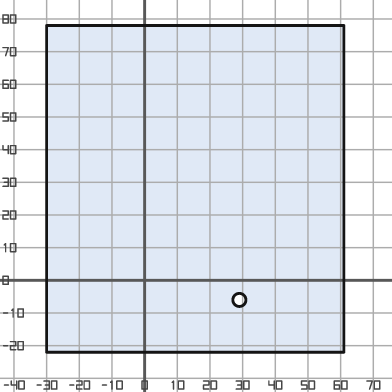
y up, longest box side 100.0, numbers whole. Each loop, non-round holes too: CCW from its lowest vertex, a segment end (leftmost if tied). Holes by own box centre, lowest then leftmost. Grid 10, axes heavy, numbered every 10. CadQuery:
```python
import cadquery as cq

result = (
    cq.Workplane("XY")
    .moveTo(-30.0, -22.0)
    .lineTo(61.0, -22.0)
    .lineTo(61.0, 78.0)
    .lineTo(-30.0, 78.0)
    .close()
    .moveTo(29.0, -6.0)
    .circle(2.0)
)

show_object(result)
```